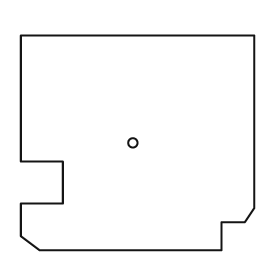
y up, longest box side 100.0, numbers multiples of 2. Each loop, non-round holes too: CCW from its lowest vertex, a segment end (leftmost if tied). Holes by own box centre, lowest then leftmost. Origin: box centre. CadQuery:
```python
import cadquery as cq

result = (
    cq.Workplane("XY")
    .moveTo(-42.0, -46.0)
    .lineTo(36.0, -46.0)
    .lineTo(36.0, -34.0)
    .lineTo(46.0, -34.0)
    .lineTo(50.0, -28.0)
    .lineTo(50.0, 46.0)
    .lineTo(-50.0, 46.0)
    .lineTo(-50.0, -8.0)
    .lineTo(-32.0, -8.0)
    .lineTo(-32.0, -26.0)
    .lineTo(-50.0, -26.0)
    .lineTo(-50.0, -40.0)
    .close()
    .moveTo(-2.0, 0.0)
    .circle(2.0)
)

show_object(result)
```